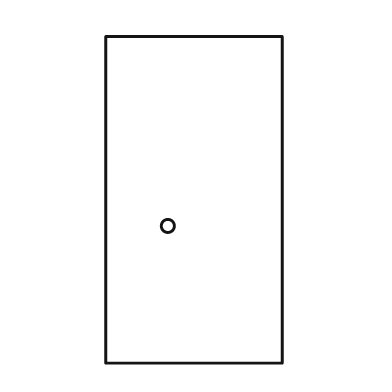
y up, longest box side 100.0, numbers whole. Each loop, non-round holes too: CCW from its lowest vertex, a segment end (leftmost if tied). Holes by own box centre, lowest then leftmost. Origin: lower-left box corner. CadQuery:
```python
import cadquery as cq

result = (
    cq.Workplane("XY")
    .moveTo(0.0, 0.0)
    .lineTo(54.0, 0.0)
    .lineTo(54.0, 100.0)
    .lineTo(0.0, 100.0)
    .close()
    .moveTo(19.0, 42.0)
    .circle(2.0)
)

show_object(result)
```